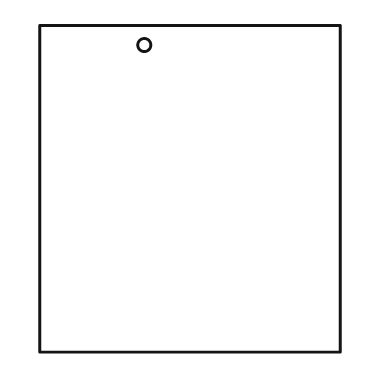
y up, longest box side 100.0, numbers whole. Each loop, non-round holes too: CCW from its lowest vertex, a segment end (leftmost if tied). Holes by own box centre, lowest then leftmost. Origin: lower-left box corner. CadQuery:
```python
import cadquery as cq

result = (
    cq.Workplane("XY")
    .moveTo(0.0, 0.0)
    .lineTo(92.0, 0.0)
    .lineTo(92.0, 100.0)
    .lineTo(0.0, 100.0)
    .close()
    .moveTo(32.0, 94.0)
    .circle(2.0)
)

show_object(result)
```